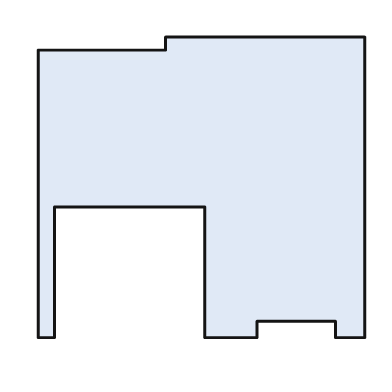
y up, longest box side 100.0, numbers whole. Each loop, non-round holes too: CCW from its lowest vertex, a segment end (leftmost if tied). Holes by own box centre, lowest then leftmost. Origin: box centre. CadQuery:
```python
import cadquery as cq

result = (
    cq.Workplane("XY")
    .moveTo(-50.0, -46.0)
    .lineTo(-45.0, -46.0)
    .lineTo(-45.0, -6.0)
    .lineTo(1.0, -6.0)
    .lineTo(1.0, -46.0)
    .lineTo(17.0, -46.0)
    .lineTo(17.0, -41.0)
    .lineTo(41.0, -41.0)
    .lineTo(41.0, -46.0)
    .lineTo(50.0, -46.0)
    .lineTo(50.0, 46.0)
    .lineTo(-11.0, 46.0)
    .lineTo(-11.0, 42.0)
    .lineTo(-50.0, 42.0)
    .close()
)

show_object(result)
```